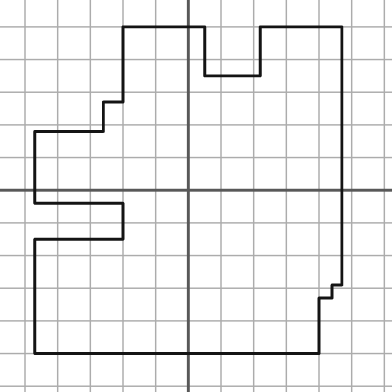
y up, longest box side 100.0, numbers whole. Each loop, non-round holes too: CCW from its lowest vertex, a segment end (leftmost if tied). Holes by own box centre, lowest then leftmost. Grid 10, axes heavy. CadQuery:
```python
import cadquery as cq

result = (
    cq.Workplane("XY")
    .moveTo(-47.0, -50.0)
    .lineTo(40.0, -50.0)
    .lineTo(40.0, -33.0)
    .lineTo(44.0, -33.0)
    .lineTo(44.0, -29.0)
    .lineTo(47.0, -29.0)
    .lineTo(47.0, 50.0)
    .lineTo(22.0, 50.0)
    .lineTo(22.0, 35.0)
    .lineTo(5.0, 35.0)
    .lineTo(5.0, 50.0)
    .lineTo(-20.0, 50.0)
    .lineTo(-20.0, 27.0)
    .lineTo(-26.0, 27.0)
    .lineTo(-26.0, 18.0)
    .lineTo(-47.0, 18.0)
    .lineTo(-47.0, -4.0)
    .lineTo(-20.0, -4.0)
    .lineTo(-20.0, -15.0)
    .lineTo(-47.0, -15.0)
    .close()
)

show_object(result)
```